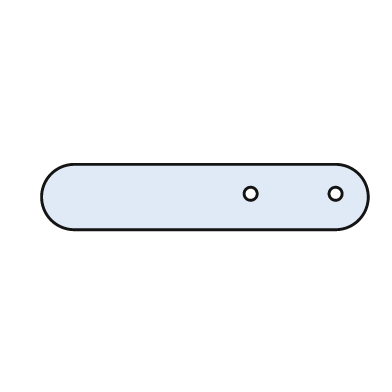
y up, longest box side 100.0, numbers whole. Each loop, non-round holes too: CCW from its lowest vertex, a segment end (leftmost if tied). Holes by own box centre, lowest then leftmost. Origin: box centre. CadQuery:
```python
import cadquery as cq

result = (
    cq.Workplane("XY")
    .moveTo(-40.0, -10.0)
    .lineTo(40.0, -10.0)
    .threePointArc((50.0, 0.0), (40.0, 10.0))
    .lineTo(-40.0, 10.0)
    .threePointArc((-50.0, 0.0), (-40.0, -10.0))
    .close()
    .moveTo(14.0, 1.0)
    .circle(2.0)
    .moveTo(40.0, 1.0)
    .circle(2.0)
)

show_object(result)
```